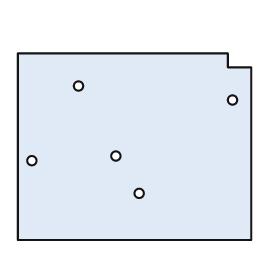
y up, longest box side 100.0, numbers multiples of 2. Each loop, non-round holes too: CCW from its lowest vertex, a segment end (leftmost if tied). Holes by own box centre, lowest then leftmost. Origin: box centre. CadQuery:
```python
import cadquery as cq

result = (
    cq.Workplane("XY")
    .moveTo(-50.0, -40.0)
    .lineTo(50.0, -40.0)
    .lineTo(50.0, 34.0)
    .lineTo(40.0, 34.0)
    .lineTo(40.0, 40.0)
    .lineTo(-50.0, 40.0)
    .close()
    .moveTo(2.0, -20.0)
    .circle(2.0)
    .moveTo(-44.0, -6.0)
    .circle(2.0)
    .moveTo(-8.0, -4.0)
    .circle(2.0)
    .moveTo(42.0, 20.0)
    .circle(2.0)
    .moveTo(-24.0, 26.0)
    .circle(2.0)
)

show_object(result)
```